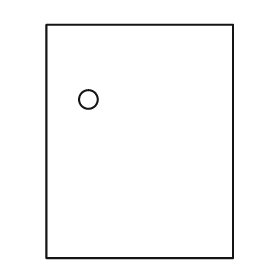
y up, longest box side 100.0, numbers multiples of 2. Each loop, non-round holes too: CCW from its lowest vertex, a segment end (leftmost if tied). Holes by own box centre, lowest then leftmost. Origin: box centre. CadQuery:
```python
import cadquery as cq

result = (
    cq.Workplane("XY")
    .moveTo(-40.0, -50.0)
    .lineTo(40.0, -50.0)
    .lineTo(40.0, 50.0)
    .lineTo(-40.0, 50.0)
    .close()
    .moveTo(-22.0, 18.0)
    .circle(4.0)
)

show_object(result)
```